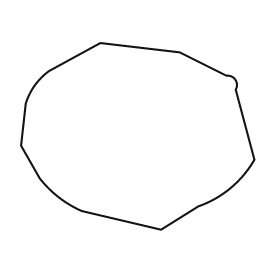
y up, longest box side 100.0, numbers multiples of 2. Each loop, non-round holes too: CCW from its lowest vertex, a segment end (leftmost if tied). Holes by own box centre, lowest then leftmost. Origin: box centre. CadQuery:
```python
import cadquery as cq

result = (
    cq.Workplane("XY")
    .moveTo(10.0, -40.0)
    .lineTo(26.0, -30.0)
    .threePointArc((40.0, -22.0), (50.0, -10.0))
    .lineTo(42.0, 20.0)
    .threePointArc((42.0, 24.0), (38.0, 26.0))
    .lineTo(18.0, 36.0)
    .lineTo(-16.0, 40.0)
    .lineTo(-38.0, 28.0)
    .threePointArc((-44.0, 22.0), (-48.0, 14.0))
    .lineTo(-50.0, -4.0)
    .lineTo(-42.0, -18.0)
    .threePointArc((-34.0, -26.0), (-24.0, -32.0))
    .close()
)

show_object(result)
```